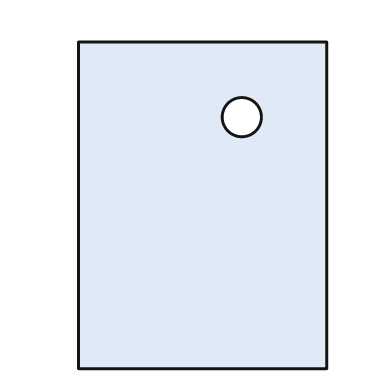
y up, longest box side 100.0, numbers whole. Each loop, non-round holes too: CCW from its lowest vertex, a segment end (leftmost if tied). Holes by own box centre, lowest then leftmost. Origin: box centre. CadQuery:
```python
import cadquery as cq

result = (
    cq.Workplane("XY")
    .moveTo(-38.0, -50.0)
    .lineTo(38.0, -50.0)
    .lineTo(38.0, 50.0)
    .lineTo(-38.0, 50.0)
    .close()
    .moveTo(12.0, 27.0)
    .circle(6.0)
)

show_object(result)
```